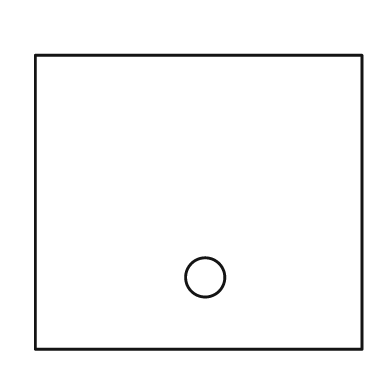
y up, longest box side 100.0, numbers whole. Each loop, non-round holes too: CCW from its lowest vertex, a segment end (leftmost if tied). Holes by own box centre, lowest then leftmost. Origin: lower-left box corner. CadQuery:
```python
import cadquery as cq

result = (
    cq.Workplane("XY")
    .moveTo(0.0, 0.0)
    .lineTo(100.0, 0.0)
    .lineTo(100.0, 90.0)
    .lineTo(0.0, 90.0)
    .close()
    .moveTo(52.0, 22.0)
    .circle(6.0)
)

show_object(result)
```